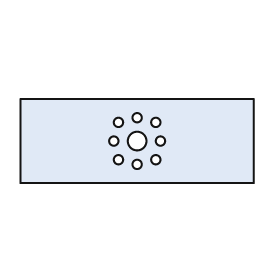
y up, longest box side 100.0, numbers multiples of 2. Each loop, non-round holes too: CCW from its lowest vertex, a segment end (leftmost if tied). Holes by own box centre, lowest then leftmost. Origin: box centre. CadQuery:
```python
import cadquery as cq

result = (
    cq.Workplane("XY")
    .moveTo(-50.0, -18.0)
    .lineTo(50.0, -18.0)
    .lineTo(50.0, 18.0)
    .lineTo(-50.0, 18.0)
    .close()
    .moveTo(0.0, -10.0)
    .circle(2.0)
    .moveTo(-8.0, -8.0)
    .circle(2.0)
    .moveTo(8.0, -8.0)
    .circle(2.0)
    .moveTo(-10.0, 0.0)
    .circle(2.0)
    .moveTo(0.0, 0.0)
    .circle(4.0)
    .moveTo(10.0, 0.0)
    .circle(2.0)
    .moveTo(-8.0, 8.0)
    .circle(2.0)
    .moveTo(8.0, 8.0)
    .circle(2.0)
    .moveTo(0.0, 10.0)
    .circle(2.0)
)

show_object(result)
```